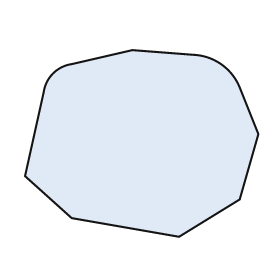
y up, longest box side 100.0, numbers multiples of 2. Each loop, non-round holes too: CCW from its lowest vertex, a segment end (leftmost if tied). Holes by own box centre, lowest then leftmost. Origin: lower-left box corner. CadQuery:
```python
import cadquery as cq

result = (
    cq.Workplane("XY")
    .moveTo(66.0, 0.0)
    .lineTo(92.0, 16.0)
    .lineTo(100.0, 44.0)
    .lineTo(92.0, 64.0)
    .threePointArc((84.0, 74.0), (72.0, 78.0))
    .lineTo(46.0, 80.0)
    .lineTo(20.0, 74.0)
    .threePointArc((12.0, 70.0), (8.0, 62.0))
    .lineTo(0.0, 26.0)
    .lineTo(20.0, 8.0)
    .close()
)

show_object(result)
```